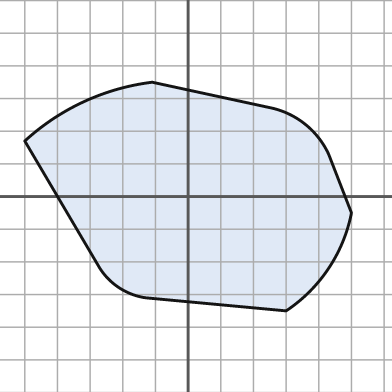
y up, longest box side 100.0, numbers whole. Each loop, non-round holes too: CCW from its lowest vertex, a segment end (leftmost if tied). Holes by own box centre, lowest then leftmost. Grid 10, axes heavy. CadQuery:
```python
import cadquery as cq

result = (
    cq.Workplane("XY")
    .moveTo(30.0, -35.0)
    .threePointArc((43.0, -22.0), (50.0, -5.0))
    .lineTo(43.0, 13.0)
    .threePointArc((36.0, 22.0), (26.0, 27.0))
    .lineTo(-11.0, 35.0)
    .threePointArc((-32.0, 29.0), (-50.0, 17.0))
    .lineTo(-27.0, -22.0)
    .threePointArc((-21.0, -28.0), (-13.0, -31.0))
    .close()
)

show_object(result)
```